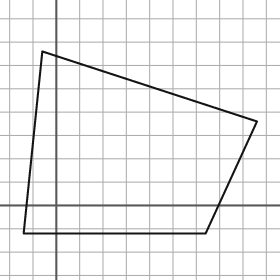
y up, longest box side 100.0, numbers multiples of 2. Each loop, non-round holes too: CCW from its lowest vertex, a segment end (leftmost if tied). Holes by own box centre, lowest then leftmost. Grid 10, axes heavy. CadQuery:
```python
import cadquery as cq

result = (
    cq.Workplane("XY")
    .moveTo(-14.0, -12.0)
    .lineTo(64.0, -12.0)
    .lineTo(86.0, 36.0)
    .lineTo(-6.0, 66.0)
    .close()
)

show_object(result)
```